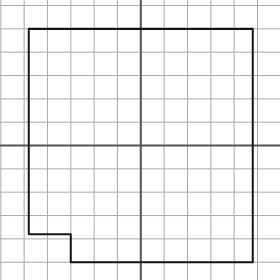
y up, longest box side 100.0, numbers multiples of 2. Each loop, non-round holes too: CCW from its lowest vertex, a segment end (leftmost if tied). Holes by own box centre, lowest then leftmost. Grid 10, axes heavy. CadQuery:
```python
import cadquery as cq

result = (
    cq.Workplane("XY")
    .moveTo(-30.0, -50.0)
    .lineTo(48.0, -50.0)
    .lineTo(48.0, 50.0)
    .lineTo(-48.0, 50.0)
    .lineTo(-48.0, -38.0)
    .lineTo(-30.0, -38.0)
    .close()
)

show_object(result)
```